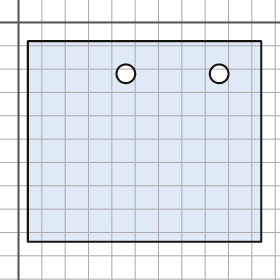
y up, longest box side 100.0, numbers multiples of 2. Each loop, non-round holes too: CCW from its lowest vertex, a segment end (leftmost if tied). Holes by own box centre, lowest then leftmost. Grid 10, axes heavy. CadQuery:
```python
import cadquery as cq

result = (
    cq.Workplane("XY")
    .moveTo(4.0, -94.0)
    .lineTo(104.0, -94.0)
    .lineTo(104.0, -8.0)
    .lineTo(4.0, -8.0)
    .close()
    .moveTo(46.0, -22.0)
    .circle(4.0)
    .moveTo(86.0, -22.0)
    .circle(4.0)
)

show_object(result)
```